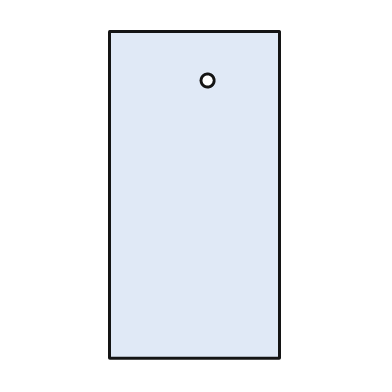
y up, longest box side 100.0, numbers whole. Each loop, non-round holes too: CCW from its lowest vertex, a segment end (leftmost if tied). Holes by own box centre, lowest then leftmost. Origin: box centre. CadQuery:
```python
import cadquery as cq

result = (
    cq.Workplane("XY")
    .moveTo(-26.0, -50.0)
    .lineTo(26.0, -50.0)
    .lineTo(26.0, 50.0)
    .lineTo(-26.0, 50.0)
    .close()
    .moveTo(4.0, 35.0)
    .circle(2.0)
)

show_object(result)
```